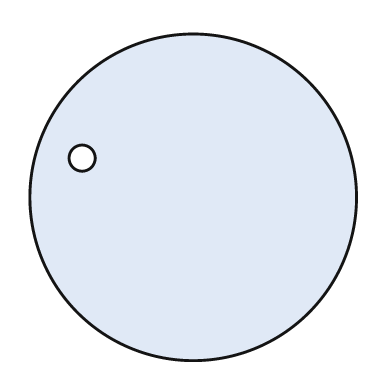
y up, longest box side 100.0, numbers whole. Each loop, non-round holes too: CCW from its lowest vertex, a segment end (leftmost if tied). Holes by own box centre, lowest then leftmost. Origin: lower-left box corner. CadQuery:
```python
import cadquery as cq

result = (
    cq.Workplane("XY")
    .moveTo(50.0, 50.0)
    .circle(50.0)
    .moveTo(16.0, 62.0)
    .circle(4.0)
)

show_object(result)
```